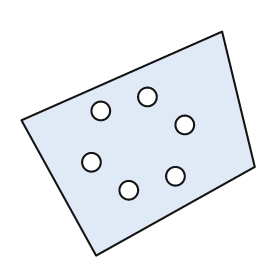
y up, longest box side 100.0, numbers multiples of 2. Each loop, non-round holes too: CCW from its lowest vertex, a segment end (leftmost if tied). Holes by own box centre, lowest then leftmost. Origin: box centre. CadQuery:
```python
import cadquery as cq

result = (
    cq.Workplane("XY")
    .moveTo(-18.0, -48.0)
    .lineTo(50.0, -10.0)
    .lineTo(36.0, 48.0)
    .lineTo(-50.0, 10.0)
    .close()
    .moveTo(-4.0, -20.0)
    .circle(4.0)
    .moveTo(16.0, -14.0)
    .circle(4.0)
    .moveTo(-20.0, -8.0)
    .circle(4.0)
    .moveTo(20.0, 8.0)
    .circle(4.0)
    .moveTo(-16.0, 14.0)
    .circle(4.0)
    .moveTo(4.0, 20.0)
    .circle(4.0)
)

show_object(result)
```